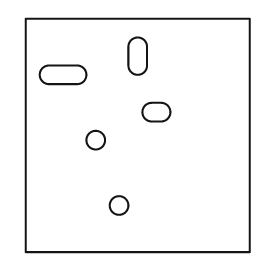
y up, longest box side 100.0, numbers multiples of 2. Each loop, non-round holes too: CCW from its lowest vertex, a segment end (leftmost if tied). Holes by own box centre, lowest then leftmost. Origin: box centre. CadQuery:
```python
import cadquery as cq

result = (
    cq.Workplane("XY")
    .moveTo(-48.0, -50.0)
    .lineTo(48.0, -50.0)
    .lineTo(48.0, 50.0)
    .lineTo(-48.0, 50.0)
    .close()
    .moveTo(-8.0, -30.0)
    .circle(4.0)
    .moveTo(-18.0, -2.0)
    .circle(4.0)
    .moveTo(6.0, 6.0)
    .lineTo(10.0, 6.0)
    .threePointArc((14.0, 10.0), (10.0, 14.0))
    .lineTo(6.0, 14.0)
    .threePointArc((2.0, 10.0), (6.0, 6.0))
    .close()
    .moveTo(-38.0, 22.0)
    .lineTo(-26.0, 22.0)
    .threePointArc((-22.0, 26.0), (-26.0, 30.0))
    .lineTo(-38.0, 30.0)
    .threePointArc((-42.0, 26.0), (-38.0, 22.0))
    .close()
    .moveTo(-4.0, 30.0)
    .threePointArc((0.0, 26.0), (4.0, 30.0))
    .lineTo(4.0, 38.0)
    .threePointArc((0.0, 42.0), (-4.0, 38.0))
    .close()
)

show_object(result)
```